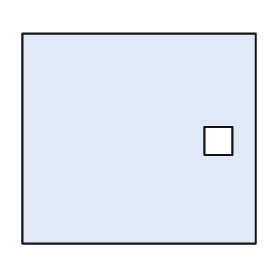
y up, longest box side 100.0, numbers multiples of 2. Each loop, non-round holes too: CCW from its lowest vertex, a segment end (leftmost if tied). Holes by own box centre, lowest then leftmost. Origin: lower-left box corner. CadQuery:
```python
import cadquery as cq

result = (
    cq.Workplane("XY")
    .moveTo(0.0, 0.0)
    .lineTo(100.0, 0.0)
    .lineTo(100.0, 90.0)
    .lineTo(0.0, 90.0)
    .close()
    .moveTo(78.0, 38.0)
    .lineTo(90.0, 38.0)
    .lineTo(90.0, 50.0)
    .lineTo(78.0, 50.0)
    .close()
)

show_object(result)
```